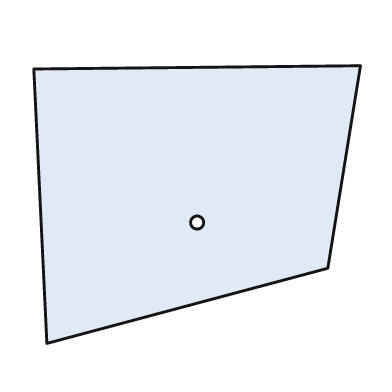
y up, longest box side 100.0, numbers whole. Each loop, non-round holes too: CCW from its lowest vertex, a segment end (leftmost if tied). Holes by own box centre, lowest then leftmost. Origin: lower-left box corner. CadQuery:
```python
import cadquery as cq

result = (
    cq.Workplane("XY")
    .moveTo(4.0, 0.0)
    .lineTo(90.0, 23.0)
    .lineTo(100.0, 85.0)
    .lineTo(0.0, 84.0)
    .close()
    .moveTo(50.0, 37.0)
    .circle(2.0)
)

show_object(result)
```